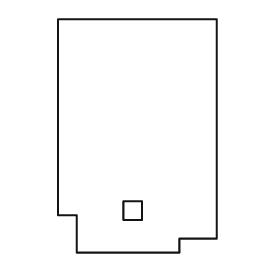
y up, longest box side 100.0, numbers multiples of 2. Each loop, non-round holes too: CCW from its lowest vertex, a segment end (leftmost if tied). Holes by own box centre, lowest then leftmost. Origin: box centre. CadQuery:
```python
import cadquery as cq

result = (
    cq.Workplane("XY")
    .moveTo(-26.0, -50.0)
    .lineTo(18.0, -50.0)
    .lineTo(18.0, -44.0)
    .lineTo(34.0, -44.0)
    .lineTo(34.0, 50.0)
    .lineTo(-34.0, 50.0)
    .lineTo(-34.0, -34.0)
    .lineTo(-26.0, -34.0)
    .close()
    .moveTo(-6.0, -36.0)
    .lineTo(2.0, -36.0)
    .lineTo(2.0, -28.0)
    .lineTo(-6.0, -28.0)
    .close()
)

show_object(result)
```